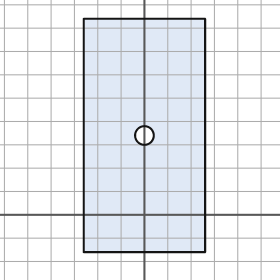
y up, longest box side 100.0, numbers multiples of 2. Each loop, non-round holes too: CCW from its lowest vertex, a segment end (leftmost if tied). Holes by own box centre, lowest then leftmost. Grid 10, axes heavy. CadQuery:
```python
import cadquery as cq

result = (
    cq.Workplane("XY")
    .moveTo(-26.0, -16.0)
    .lineTo(26.0, -16.0)
    .lineTo(26.0, 84.0)
    .lineTo(-26.0, 84.0)
    .close()
    .moveTo(0.0, 34.0)
    .circle(4.0)
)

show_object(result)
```